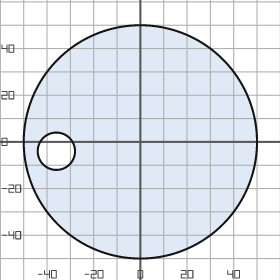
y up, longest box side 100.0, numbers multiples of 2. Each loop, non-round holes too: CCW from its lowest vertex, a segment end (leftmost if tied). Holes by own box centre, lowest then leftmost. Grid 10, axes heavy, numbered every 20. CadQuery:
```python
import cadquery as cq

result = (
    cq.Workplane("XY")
    .moveTo(0.0, 0.0)
    .circle(50.0)
    .moveTo(-36.0, -4.0)
    .circle(8.0)
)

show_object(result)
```